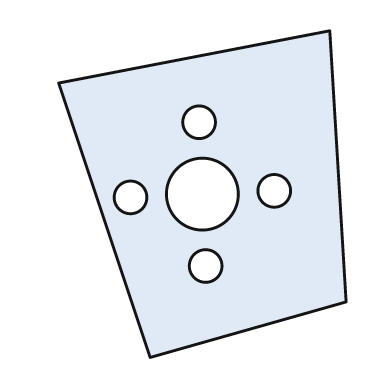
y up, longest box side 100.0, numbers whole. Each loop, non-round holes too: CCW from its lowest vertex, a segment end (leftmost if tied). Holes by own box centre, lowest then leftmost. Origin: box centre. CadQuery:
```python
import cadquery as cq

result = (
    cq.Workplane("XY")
    .moveTo(-16.0, -50.0)
    .lineTo(44.0, -33.0)
    .lineTo(39.0, 50.0)
    .lineTo(-44.0, 34.0)
    .close()
    .moveTo(1.0, -22.0)
    .circle(5.0)
    .moveTo(-22.0, -1.0)
    .circle(5.0)
    .moveTo(0.0, 0.0)
    .circle(11.0)
    .moveTo(22.0, 1.0)
    .circle(5.0)
    .moveTo(-1.0, 22.0)
    .circle(5.0)
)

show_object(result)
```